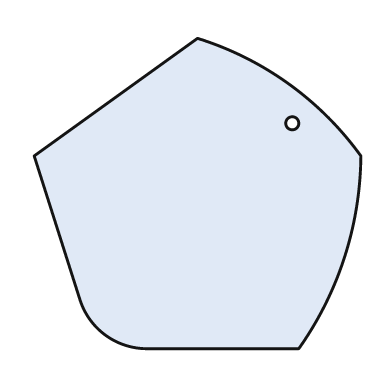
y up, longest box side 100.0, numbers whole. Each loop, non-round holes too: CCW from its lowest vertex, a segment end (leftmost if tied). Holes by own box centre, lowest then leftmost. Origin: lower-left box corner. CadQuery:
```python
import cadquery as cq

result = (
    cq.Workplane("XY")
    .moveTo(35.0, 0.0)
    .lineTo(81.0, 0.0)
    .threePointArc((95.0, 28.0), (100.0, 59.0))
    .threePointArc((78.0, 81.0), (50.0, 95.0))
    .lineTo(0.0, 59.0)
    .lineTo(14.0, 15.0)
    .threePointArc((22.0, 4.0), (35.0, 0.0))
    .close()
    .moveTo(79.0, 69.0)
    .circle(2.0)
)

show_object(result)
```